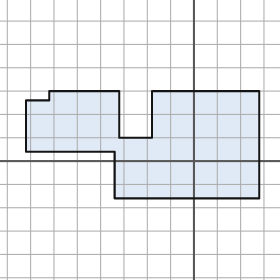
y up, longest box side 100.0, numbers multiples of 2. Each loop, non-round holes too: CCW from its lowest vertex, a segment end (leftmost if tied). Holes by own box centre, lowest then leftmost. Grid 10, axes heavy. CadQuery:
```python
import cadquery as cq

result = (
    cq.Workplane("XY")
    .moveTo(-34.0, -16.0)
    .lineTo(28.0, -16.0)
    .lineTo(28.0, 30.0)
    .lineTo(-18.0, 30.0)
    .lineTo(-18.0, 10.0)
    .lineTo(-32.0, 10.0)
    .lineTo(-32.0, 30.0)
    .lineTo(-62.0, 30.0)
    .lineTo(-62.0, 26.0)
    .lineTo(-72.0, 26.0)
    .lineTo(-72.0, 4.0)
    .lineTo(-34.0, 4.0)
    .close()
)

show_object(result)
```